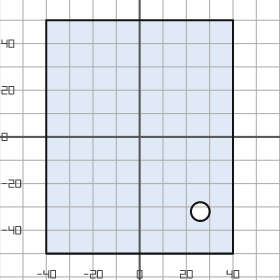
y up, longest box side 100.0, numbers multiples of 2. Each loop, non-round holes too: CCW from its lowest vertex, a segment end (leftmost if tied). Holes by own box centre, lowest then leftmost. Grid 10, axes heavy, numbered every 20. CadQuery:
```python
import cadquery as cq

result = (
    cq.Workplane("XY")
    .moveTo(-40.0, -50.0)
    .lineTo(40.0, -50.0)
    .lineTo(40.0, 50.0)
    .lineTo(-40.0, 50.0)
    .close()
    .moveTo(26.0, -32.0)
    .circle(4.0)
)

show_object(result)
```